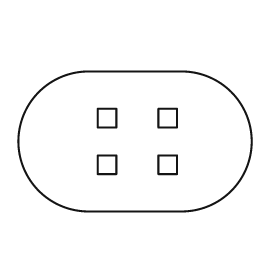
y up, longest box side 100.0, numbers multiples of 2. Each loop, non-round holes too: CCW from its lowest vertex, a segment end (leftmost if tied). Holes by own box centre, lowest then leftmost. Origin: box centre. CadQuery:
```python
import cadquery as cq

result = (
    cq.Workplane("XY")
    .moveTo(-20.0, -30.0)
    .lineTo(20.0, -30.0)
    .threePointArc((50.0, 0.0), (20.0, 30.0))
    .lineTo(-20.0, 30.0)
    .threePointArc((-50.0, 0.0), (-20.0, -30.0))
    .close()
    .moveTo(-16.0, -14.0)
    .lineTo(-8.0, -14.0)
    .lineTo(-8.0, -6.0)
    .lineTo(-16.0, -6.0)
    .close()
    .moveTo(10.0, -14.0)
    .lineTo(18.0, -14.0)
    .lineTo(18.0, -6.0)
    .lineTo(10.0, -6.0)
    .close()
    .moveTo(-16.0, 6.0)
    .lineTo(-8.0, 6.0)
    .lineTo(-8.0, 14.0)
    .lineTo(-16.0, 14.0)
    .close()
    .moveTo(10.0, 6.0)
    .lineTo(18.0, 6.0)
    .lineTo(18.0, 14.0)
    .lineTo(10.0, 14.0)
    .close()
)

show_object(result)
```